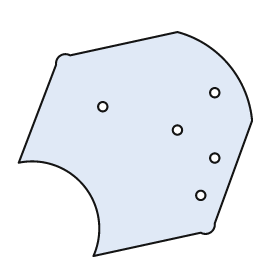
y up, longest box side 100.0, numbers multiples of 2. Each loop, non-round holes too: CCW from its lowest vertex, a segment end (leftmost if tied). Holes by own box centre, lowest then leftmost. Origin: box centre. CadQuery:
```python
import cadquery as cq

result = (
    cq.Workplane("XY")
    .moveTo(-18.0, -48.0)
    .lineTo(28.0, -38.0)
    .threePointArc((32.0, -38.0), (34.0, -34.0))
    .lineTo(50.0, 10.0)
    .threePointArc((40.0, 34.0), (18.0, 48.0))
    .lineTo(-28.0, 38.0)
    .threePointArc((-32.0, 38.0), (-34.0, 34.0))
    .lineTo(-50.0, -8.0)
    .threePointArc((-22.0, -18.0), (-18.0, -48.0))
    .close()
    .moveTo(28.0, -22.0)
    .circle(2.0)
    .moveTo(34.0, -6.0)
    .circle(2.0)
    .moveTo(18.0, 6.0)
    .circle(2.0)
    .moveTo(-14.0, 16.0)
    .circle(2.0)
    .moveTo(34.0, 22.0)
    .circle(2.0)
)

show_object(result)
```